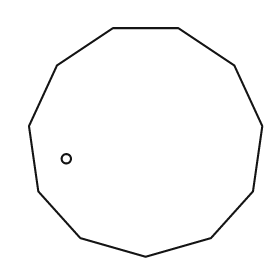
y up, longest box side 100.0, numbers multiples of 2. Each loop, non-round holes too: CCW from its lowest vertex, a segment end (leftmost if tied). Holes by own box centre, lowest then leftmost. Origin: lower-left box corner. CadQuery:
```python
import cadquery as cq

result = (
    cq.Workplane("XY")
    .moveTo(50.0, 0.0)
    .lineTo(78.0, 8.0)
    .lineTo(96.0, 28.0)
    .lineTo(100.0, 56.0)
    .lineTo(88.0, 82.0)
    .lineTo(64.0, 98.0)
    .lineTo(36.0, 98.0)
    .lineTo(12.0, 82.0)
    .lineTo(0.0, 56.0)
    .lineTo(4.0, 28.0)
    .lineTo(22.0, 8.0)
    .close()
    .moveTo(16.0, 42.0)
    .circle(2.0)
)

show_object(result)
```